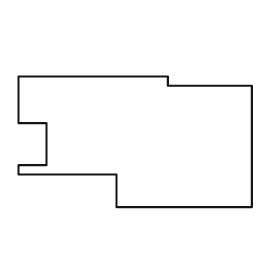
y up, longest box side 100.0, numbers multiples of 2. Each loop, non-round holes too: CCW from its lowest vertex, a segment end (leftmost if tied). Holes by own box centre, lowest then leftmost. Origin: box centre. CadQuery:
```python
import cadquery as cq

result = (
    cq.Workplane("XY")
    .moveTo(-8.0, -28.0)
    .lineTo(50.0, -28.0)
    .lineTo(50.0, 24.0)
    .lineTo(14.0, 24.0)
    .lineTo(14.0, 28.0)
    .lineTo(-50.0, 28.0)
    .lineTo(-50.0, 8.0)
    .lineTo(-38.0, 8.0)
    .lineTo(-38.0, -10.0)
    .lineTo(-50.0, -10.0)
    .lineTo(-50.0, -14.0)
    .lineTo(-8.0, -14.0)
    .close()
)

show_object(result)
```